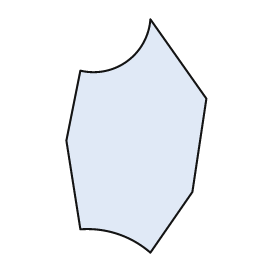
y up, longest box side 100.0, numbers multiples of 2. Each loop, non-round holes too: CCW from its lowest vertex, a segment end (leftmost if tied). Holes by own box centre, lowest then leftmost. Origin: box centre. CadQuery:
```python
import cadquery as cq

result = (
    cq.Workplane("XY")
    .moveTo(6.0, -50.0)
    .lineTo(24.0, -24.0)
    .lineTo(30.0, 16.0)
    .lineTo(6.0, 50.0)
    .threePointArc((-4.0, 32.0), (-24.0, 28.0))
    .lineTo(-30.0, -2.0)
    .lineTo(-24.0, -40.0)
    .threePointArc((-8.0, -42.0), (6.0, -50.0))
    .close()
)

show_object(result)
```